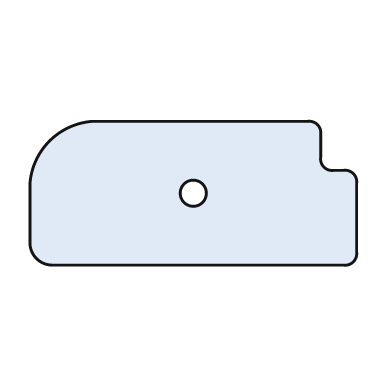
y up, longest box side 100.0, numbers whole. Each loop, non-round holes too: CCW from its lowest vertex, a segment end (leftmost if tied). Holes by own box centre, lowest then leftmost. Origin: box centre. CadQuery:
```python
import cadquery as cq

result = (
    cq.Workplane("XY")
    .moveTo(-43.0, -22.0)
    .lineTo(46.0, -22.0)
    .threePointArc((49.0, -21.0), (50.0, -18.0))
    .lineTo(50.0, 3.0)
    .threePointArc((49.0, 6.0), (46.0, 7.0))
    .lineTo(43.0, 7.0)
    .threePointArc((40.0, 8.0), (39.0, 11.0))
    .lineTo(39.0, 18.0)
    .threePointArc((38.0, 21.0), (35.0, 22.0))
    .lineTo(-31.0, 22.0)
    .threePointArc((-44.0, 16.0), (-50.0, 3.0))
    .lineTo(-50.0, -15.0)
    .threePointArc((-48.0, -20.0), (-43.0, -22.0))
    .close()
    .moveTo(0.0, 0.0)
    .circle(4.0)
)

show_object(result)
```